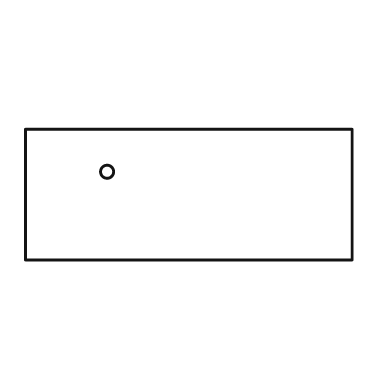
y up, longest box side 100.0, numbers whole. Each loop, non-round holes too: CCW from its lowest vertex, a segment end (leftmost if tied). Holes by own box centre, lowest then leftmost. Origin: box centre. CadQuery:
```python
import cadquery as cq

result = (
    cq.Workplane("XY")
    .moveTo(-50.0, -20.0)
    .lineTo(50.0, -20.0)
    .lineTo(50.0, 20.0)
    .lineTo(-50.0, 20.0)
    .close()
    .moveTo(-25.0, 7.0)
    .circle(2.0)
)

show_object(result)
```